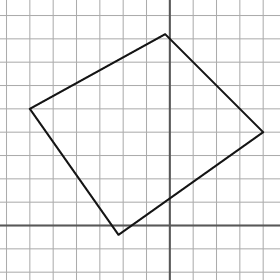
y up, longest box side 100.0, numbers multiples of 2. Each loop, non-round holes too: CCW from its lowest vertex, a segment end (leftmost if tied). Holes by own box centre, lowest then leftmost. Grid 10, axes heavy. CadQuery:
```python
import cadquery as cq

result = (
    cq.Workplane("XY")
    .moveTo(-22.0, -4.0)
    .lineTo(40.0, 40.0)
    .lineTo(-2.0, 82.0)
    .lineTo(-60.0, 50.0)
    .close()
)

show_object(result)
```